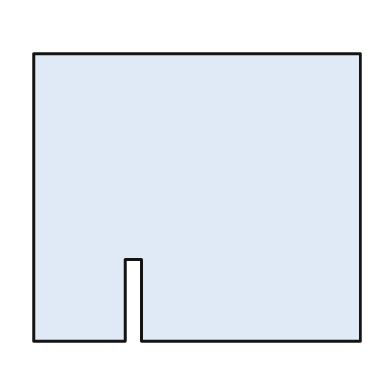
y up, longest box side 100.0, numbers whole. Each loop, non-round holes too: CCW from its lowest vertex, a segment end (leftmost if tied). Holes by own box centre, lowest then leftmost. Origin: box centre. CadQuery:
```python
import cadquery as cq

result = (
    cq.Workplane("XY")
    .moveTo(-50.0, -44.0)
    .lineTo(-22.0, -44.0)
    .lineTo(-22.0, -19.0)
    .lineTo(-17.0, -19.0)
    .lineTo(-17.0, -44.0)
    .lineTo(50.0, -44.0)
    .lineTo(50.0, 44.0)
    .lineTo(-50.0, 44.0)
    .close()
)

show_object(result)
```